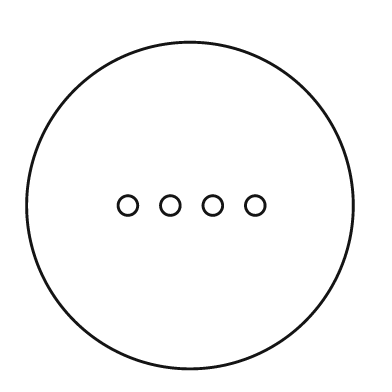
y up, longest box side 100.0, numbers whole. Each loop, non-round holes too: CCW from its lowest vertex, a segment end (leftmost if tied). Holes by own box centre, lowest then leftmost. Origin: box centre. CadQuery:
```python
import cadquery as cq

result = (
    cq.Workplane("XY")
    .moveTo(0.0, 0.0)
    .circle(50.0)
    .moveTo(-19.0, 0.0)
    .circle(3.0)
    .moveTo(-6.0, 0.0)
    .circle(3.0)
    .moveTo(7.0, 0.0)
    .circle(3.0)
    .moveTo(20.0, 0.0)
    .circle(3.0)
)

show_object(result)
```